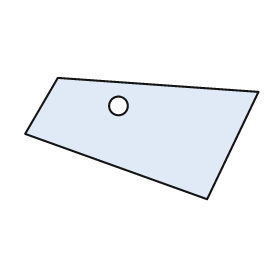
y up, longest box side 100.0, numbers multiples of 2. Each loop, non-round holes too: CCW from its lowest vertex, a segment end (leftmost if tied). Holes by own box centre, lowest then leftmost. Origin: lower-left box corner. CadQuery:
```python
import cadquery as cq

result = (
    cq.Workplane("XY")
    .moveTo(78.0, 0.0)
    .lineTo(100.0, 46.0)
    .lineTo(14.0, 52.0)
    .lineTo(0.0, 28.0)
    .close()
    .moveTo(40.0, 40.0)
    .circle(4.0)
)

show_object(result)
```